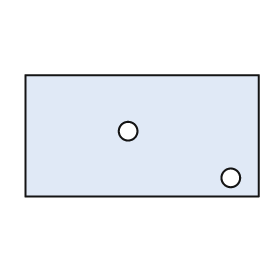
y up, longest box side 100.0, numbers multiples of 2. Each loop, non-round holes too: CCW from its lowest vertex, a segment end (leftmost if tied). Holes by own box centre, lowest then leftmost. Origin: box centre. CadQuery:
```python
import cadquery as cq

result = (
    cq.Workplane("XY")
    .moveTo(-50.0, -26.0)
    .lineTo(50.0, -26.0)
    .lineTo(50.0, 26.0)
    .lineTo(-50.0, 26.0)
    .close()
    .moveTo(38.0, -18.0)
    .circle(4.0)
    .moveTo(-6.0, 2.0)
    .circle(4.0)
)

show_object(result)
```